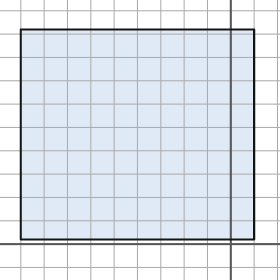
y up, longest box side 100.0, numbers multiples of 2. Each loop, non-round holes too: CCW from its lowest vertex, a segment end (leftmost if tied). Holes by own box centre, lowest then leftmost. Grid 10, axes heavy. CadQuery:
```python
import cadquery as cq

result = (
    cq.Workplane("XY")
    .moveTo(-90.0, 2.0)
    .lineTo(10.0, 2.0)
    .lineTo(10.0, 92.0)
    .lineTo(-90.0, 92.0)
    .close()
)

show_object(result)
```